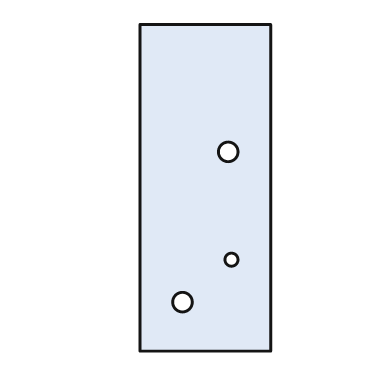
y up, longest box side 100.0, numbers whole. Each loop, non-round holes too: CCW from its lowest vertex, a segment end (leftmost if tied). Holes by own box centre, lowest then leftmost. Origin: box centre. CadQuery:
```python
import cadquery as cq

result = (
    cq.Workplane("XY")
    .moveTo(-20.0, -50.0)
    .lineTo(20.0, -50.0)
    .lineTo(20.0, 50.0)
    .lineTo(-20.0, 50.0)
    .close()
    .moveTo(-7.0, -35.0)
    .circle(3.0)
    .moveTo(8.0, -22.0)
    .circle(2.0)
    .moveTo(7.0, 11.0)
    .circle(3.0)
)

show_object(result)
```